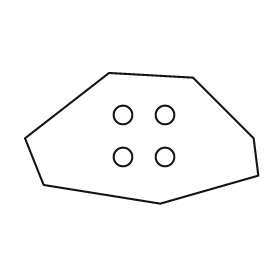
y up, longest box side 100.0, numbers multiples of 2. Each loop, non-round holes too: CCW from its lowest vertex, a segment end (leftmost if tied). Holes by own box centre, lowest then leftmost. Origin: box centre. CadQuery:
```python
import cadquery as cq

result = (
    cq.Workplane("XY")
    .moveTo(8.0, -28.0)
    .lineTo(50.0, -16.0)
    .lineTo(48.0, 0.0)
    .lineTo(22.0, 26.0)
    .lineTo(-14.0, 28.0)
    .lineTo(-50.0, 0.0)
    .lineTo(-42.0, -20.0)
    .close()
    .moveTo(-8.0, -8.0)
    .circle(4.0)
    .moveTo(10.0, -8.0)
    .circle(4.0)
    .moveTo(-8.0, 10.0)
    .circle(4.0)
    .moveTo(10.0, 10.0)
    .circle(4.0)
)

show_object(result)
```